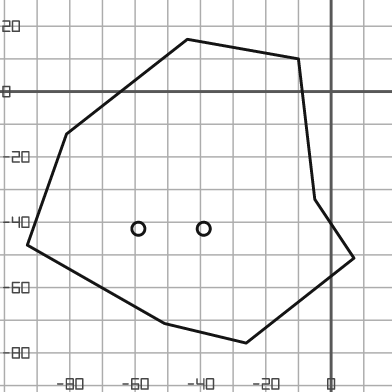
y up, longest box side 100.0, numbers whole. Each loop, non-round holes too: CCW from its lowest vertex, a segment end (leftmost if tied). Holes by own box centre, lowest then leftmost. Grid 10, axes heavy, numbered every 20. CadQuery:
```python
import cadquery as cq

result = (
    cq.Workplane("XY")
    .moveTo(-26.0, -77.0)
    .lineTo(7.0, -51.0)
    .lineTo(-5.0, -33.0)
    .lineTo(-10.0, 10.0)
    .lineTo(-44.0, 16.0)
    .lineTo(-81.0, -13.0)
    .lineTo(-93.0, -47.0)
    .lineTo(-51.0, -71.0)
    .close()
    .moveTo(-59.0, -42.0)
    .circle(2.0)
    .moveTo(-39.0, -42.0)
    .circle(2.0)
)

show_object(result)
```